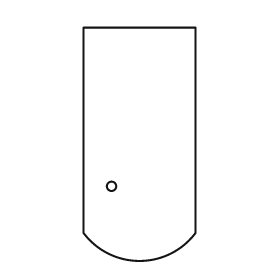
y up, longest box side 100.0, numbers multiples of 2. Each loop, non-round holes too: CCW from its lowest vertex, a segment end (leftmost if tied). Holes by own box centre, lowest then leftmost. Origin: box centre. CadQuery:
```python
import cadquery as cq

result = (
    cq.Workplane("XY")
    .moveTo(-24.0, -38.0)
    .threePointArc((0.0, -50.0), (24.0, -38.0))
    .lineTo(24.0, 50.0)
    .lineTo(-24.0, 50.0)
    .close()
    .moveTo(-12.0, -18.0)
    .circle(2.0)
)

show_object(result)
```